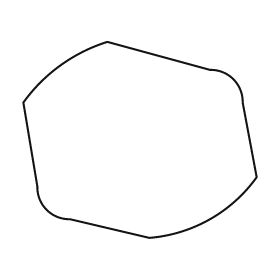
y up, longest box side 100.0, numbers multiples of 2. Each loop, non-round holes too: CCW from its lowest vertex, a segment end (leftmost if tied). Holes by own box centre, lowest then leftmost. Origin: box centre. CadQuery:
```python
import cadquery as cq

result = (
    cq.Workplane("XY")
    .moveTo(4.0, -42.0)
    .threePointArc((30.0, -34.0), (50.0, -16.0))
    .lineTo(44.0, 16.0)
    .threePointArc((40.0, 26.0), (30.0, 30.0))
    .lineTo(-14.0, 42.0)
    .threePointArc((-34.0, 32.0), (-50.0, 16.0))
    .lineTo(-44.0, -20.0)
    .threePointArc((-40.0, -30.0), (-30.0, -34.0))
    .close()
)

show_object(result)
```